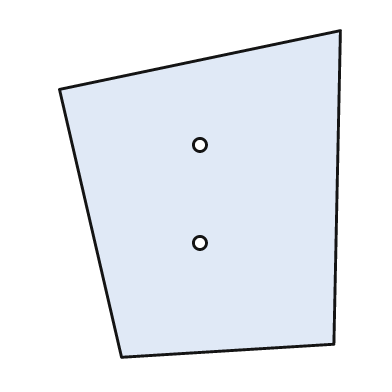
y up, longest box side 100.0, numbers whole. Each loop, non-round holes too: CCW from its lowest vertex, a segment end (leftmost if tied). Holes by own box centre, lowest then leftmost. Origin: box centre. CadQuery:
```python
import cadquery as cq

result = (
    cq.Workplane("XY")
    .moveTo(-24.0, -50.0)
    .lineTo(41.0, -46.0)
    .lineTo(43.0, 50.0)
    .lineTo(-43.0, 32.0)
    .close()
    .moveTo(0.0, -15.0)
    .circle(2.0)
    .moveTo(0.0, 15.0)
    .circle(2.0)
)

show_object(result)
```